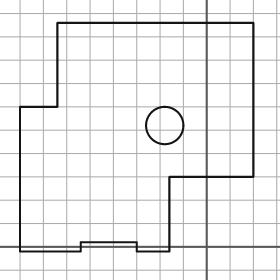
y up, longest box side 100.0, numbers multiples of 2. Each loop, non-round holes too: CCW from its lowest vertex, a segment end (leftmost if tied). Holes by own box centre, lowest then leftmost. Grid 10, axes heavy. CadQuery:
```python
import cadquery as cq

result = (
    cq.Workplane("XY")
    .moveTo(-80.0, -2.0)
    .lineTo(-54.0, -2.0)
    .lineTo(-54.0, 2.0)
    .lineTo(-30.0, 2.0)
    .lineTo(-30.0, -2.0)
    .lineTo(-16.0, -2.0)
    .lineTo(-16.0, 30.0)
    .lineTo(20.0, 30.0)
    .lineTo(20.0, 96.0)
    .lineTo(-64.0, 96.0)
    .lineTo(-64.0, 60.0)
    .lineTo(-80.0, 60.0)
    .close()
    .moveTo(-18.0, 52.0)
    .circle(8.0)
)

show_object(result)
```